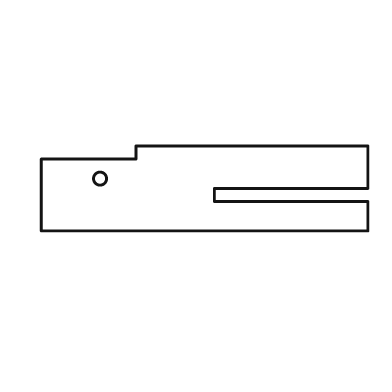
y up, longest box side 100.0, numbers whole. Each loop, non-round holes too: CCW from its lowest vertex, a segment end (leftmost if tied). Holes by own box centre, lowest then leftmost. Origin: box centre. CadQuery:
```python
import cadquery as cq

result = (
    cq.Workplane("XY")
    .moveTo(-50.0, -13.0)
    .lineTo(50.0, -13.0)
    .lineTo(50.0, -4.0)
    .lineTo(3.0, -4.0)
    .lineTo(3.0, 0.0)
    .lineTo(50.0, 0.0)
    .lineTo(50.0, 13.0)
    .lineTo(-21.0, 13.0)
    .lineTo(-21.0, 9.0)
    .lineTo(-50.0, 9.0)
    .close()
    .moveTo(-32.0, 3.0)
    .circle(2.0)
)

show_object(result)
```